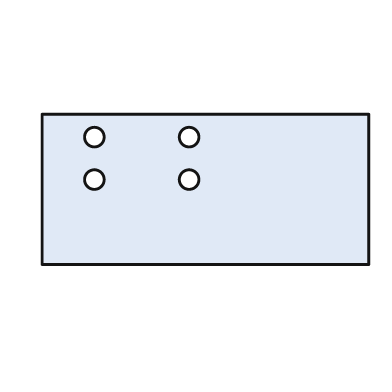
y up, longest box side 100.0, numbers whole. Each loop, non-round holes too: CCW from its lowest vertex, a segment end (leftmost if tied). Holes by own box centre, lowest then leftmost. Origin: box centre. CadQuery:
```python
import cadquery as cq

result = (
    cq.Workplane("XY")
    .moveTo(-50.0, -23.0)
    .lineTo(50.0, -23.0)
    .lineTo(50.0, 23.0)
    .lineTo(-50.0, 23.0)
    .close()
    .moveTo(-34.0, 3.0)
    .circle(3.0)
    .moveTo(-5.0, 3.0)
    .circle(3.0)
    .moveTo(-34.0, 16.0)
    .circle(3.0)
    .moveTo(-5.0, 16.0)
    .circle(3.0)
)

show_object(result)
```